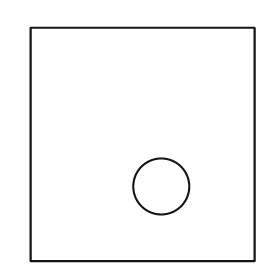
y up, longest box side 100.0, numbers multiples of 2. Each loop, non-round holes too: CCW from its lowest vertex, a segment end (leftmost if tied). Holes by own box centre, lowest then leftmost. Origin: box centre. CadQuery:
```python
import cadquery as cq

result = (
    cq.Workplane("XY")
    .moveTo(-48.0, -50.0)
    .lineTo(48.0, -50.0)
    .lineTo(48.0, 50.0)
    .lineTo(-48.0, 50.0)
    .close()
    .moveTo(8.0, -18.0)
    .circle(12.0)
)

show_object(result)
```